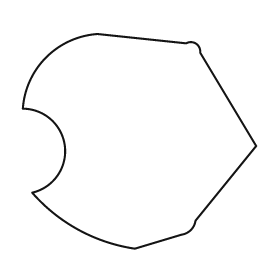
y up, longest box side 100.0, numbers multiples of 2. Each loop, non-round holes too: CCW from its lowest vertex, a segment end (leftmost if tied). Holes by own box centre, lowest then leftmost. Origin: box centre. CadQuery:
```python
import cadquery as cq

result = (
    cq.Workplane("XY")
    .moveTo(-2.0, -46.0)
    .lineTo(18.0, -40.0)
    .threePointArc((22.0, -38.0), (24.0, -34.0))
    .lineTo(50.0, -2.0)
    .lineTo(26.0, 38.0)
    .threePointArc((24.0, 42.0), (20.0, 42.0))
    .lineTo(-18.0, 46.0)
    .threePointArc((-40.0, 36.0), (-50.0, 14.0))
    .threePointArc((-32.0, -2.0), (-46.0, -22.0))
    .threePointArc((-26.0, -38.0), (-2.0, -46.0))
    .close()
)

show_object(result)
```